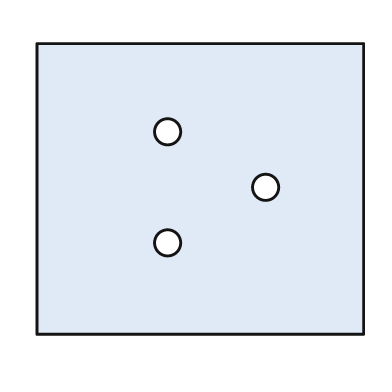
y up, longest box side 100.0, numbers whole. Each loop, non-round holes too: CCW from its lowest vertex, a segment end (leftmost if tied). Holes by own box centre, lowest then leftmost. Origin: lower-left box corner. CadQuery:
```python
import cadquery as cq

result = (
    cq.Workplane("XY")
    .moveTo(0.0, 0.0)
    .lineTo(100.0, 0.0)
    .lineTo(100.0, 89.0)
    .lineTo(0.0, 89.0)
    .close()
    .moveTo(40.0, 28.0)
    .circle(4.0)
    .moveTo(70.0, 45.0)
    .circle(4.0)
    .moveTo(40.0, 62.0)
    .circle(4.0)
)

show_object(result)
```